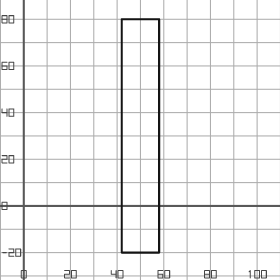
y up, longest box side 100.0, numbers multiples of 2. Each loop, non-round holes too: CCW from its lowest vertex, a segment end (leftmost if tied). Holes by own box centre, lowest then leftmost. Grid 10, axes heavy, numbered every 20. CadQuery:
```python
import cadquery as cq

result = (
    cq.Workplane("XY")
    .moveTo(42.0, -20.0)
    .lineTo(58.0, -20.0)
    .lineTo(58.0, 80.0)
    .lineTo(42.0, 80.0)
    .close()
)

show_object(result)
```